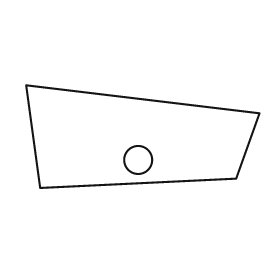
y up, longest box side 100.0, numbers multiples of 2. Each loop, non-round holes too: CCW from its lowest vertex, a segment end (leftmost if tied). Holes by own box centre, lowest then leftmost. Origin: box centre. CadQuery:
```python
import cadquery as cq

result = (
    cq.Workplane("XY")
    .moveTo(-44.0, -22.0)
    .lineTo(40.0, -18.0)
    .lineTo(50.0, 10.0)
    .lineTo(-50.0, 22.0)
    .close()
    .moveTo(-2.0, -10.0)
    .circle(6.0)
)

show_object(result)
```